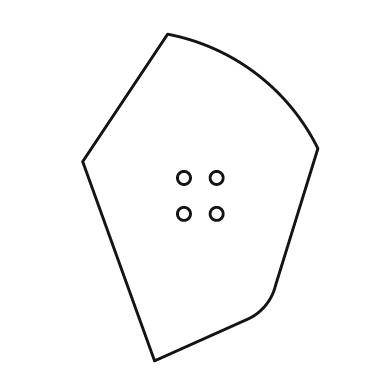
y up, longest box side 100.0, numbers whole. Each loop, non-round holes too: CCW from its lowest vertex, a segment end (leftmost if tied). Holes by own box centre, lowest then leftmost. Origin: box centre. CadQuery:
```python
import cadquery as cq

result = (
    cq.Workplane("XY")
    .moveTo(-14.0, -50.0)
    .lineTo(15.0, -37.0)
    .threePointArc((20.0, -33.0), (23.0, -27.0))
    .lineTo(36.0, 15.0)
    .threePointArc((17.0, 38.0), (-10.0, 50.0))
    .lineTo(-36.0, 11.0)
    .close()
    .moveTo(-5.0, -5.0)
    .circle(2.0)
    .moveTo(5.0, -5.0)
    .circle(2.0)
    .moveTo(-5.0, 6.0)
    .circle(2.0)
    .moveTo(5.0, 6.0)
    .circle(2.0)
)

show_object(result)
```